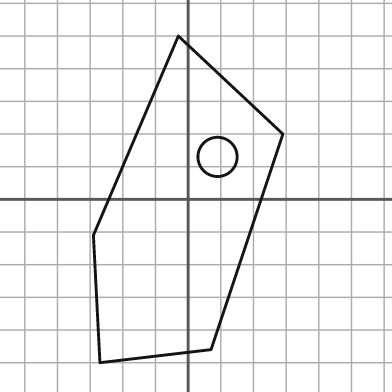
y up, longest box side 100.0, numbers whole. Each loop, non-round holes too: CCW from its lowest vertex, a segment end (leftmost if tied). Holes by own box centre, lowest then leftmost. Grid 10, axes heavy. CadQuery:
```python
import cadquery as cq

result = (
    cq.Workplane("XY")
    .moveTo(-27.0, -50.0)
    .lineTo(7.0, -46.0)
    .lineTo(29.0, 20.0)
    .lineTo(-3.0, 50.0)
    .lineTo(-29.0, -11.0)
    .close()
    .moveTo(9.0, 13.0)
    .circle(6.0)
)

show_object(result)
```